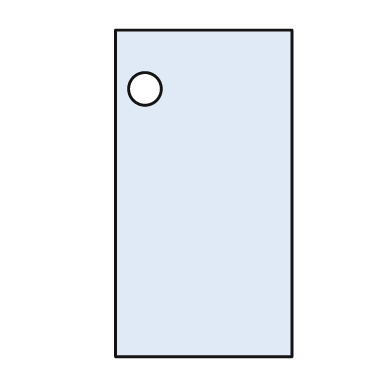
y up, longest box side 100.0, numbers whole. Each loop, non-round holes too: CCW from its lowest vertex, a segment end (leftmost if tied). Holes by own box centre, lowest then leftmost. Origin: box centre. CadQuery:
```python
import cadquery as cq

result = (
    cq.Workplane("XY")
    .moveTo(-27.0, -50.0)
    .lineTo(27.0, -50.0)
    .lineTo(27.0, 50.0)
    .lineTo(-27.0, 50.0)
    .close()
    .moveTo(-18.0, 32.0)
    .circle(5.0)
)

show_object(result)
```